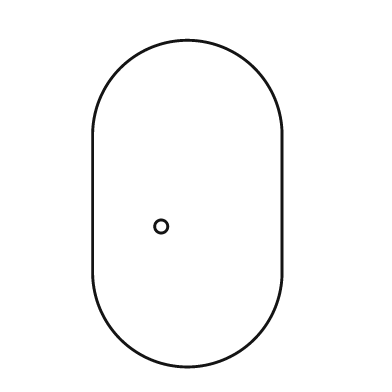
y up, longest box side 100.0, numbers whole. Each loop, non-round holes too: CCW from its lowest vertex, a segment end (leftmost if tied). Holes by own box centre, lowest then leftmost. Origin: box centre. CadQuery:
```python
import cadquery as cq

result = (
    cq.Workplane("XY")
    .moveTo(-29.0, -21.0)
    .threePointArc((0.0, -50.0), (29.0, -21.0))
    .lineTo(29.0, 21.0)
    .threePointArc((0.0, 50.0), (-29.0, 21.0))
    .close()
    .moveTo(-8.0, -7.0)
    .circle(2.0)
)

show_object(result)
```